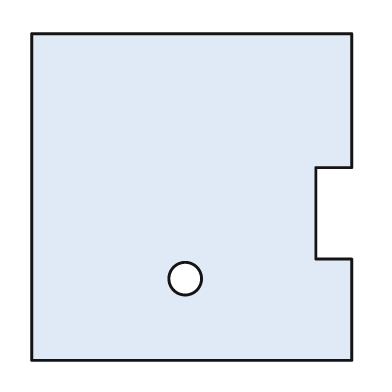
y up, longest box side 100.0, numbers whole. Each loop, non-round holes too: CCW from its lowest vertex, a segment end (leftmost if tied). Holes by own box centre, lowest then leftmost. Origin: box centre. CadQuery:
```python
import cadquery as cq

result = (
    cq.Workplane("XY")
    .moveTo(-49.0, -50.0)
    .lineTo(49.0, -50.0)
    .lineTo(49.0, -19.0)
    .lineTo(38.0, -19.0)
    .lineTo(38.0, 9.0)
    .lineTo(49.0, 9.0)
    .lineTo(49.0, 50.0)
    .lineTo(-49.0, 50.0)
    .close()
    .moveTo(-2.0, -25.0)
    .circle(5.0)
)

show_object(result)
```